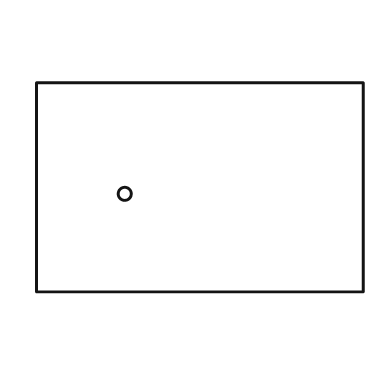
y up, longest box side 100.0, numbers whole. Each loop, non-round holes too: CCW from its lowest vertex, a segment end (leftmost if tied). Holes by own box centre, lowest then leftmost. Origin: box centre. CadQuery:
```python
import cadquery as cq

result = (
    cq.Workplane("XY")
    .moveTo(-50.0, -32.0)
    .lineTo(50.0, -32.0)
    .lineTo(50.0, 32.0)
    .lineTo(-50.0, 32.0)
    .close()
    .moveTo(-23.0, -2.0)
    .circle(2.0)
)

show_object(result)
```